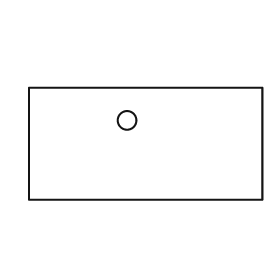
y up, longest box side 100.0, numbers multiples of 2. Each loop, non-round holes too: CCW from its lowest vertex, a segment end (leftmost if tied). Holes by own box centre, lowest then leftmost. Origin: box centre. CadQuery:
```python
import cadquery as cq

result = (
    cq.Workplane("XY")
    .moveTo(-50.0, -24.0)
    .lineTo(50.0, -24.0)
    .lineTo(50.0, 24.0)
    .lineTo(-50.0, 24.0)
    .close()
    .moveTo(-8.0, 10.0)
    .circle(4.0)
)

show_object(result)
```